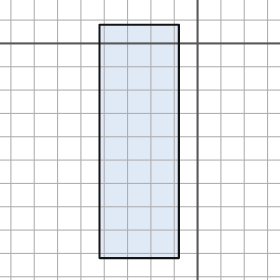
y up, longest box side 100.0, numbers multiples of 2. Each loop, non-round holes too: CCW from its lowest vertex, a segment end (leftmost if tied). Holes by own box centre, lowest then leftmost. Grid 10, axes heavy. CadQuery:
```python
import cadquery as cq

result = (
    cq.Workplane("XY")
    .moveTo(-42.0, -92.0)
    .lineTo(-8.0, -92.0)
    .lineTo(-8.0, 8.0)
    .lineTo(-42.0, 8.0)
    .close()
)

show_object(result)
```